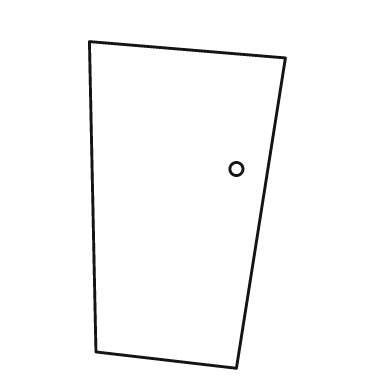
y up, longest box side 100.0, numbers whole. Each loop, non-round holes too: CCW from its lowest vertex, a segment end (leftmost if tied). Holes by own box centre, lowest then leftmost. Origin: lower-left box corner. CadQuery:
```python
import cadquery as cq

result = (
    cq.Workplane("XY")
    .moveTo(45.0, 0.0)
    .lineTo(60.0, 95.0)
    .lineTo(0.0, 100.0)
    .lineTo(2.0, 5.0)
    .close()
    .moveTo(45.0, 61.0)
    .circle(2.0)
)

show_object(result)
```